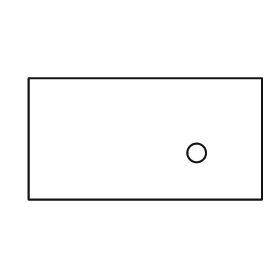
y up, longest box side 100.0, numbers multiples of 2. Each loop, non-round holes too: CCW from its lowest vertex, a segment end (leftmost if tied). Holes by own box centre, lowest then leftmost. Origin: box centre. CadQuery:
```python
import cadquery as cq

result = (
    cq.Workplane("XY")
    .moveTo(-50.0, -26.0)
    .lineTo(50.0, -26.0)
    .lineTo(50.0, 26.0)
    .lineTo(-50.0, 26.0)
    .close()
    .moveTo(22.0, -6.0)
    .circle(4.0)
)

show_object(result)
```